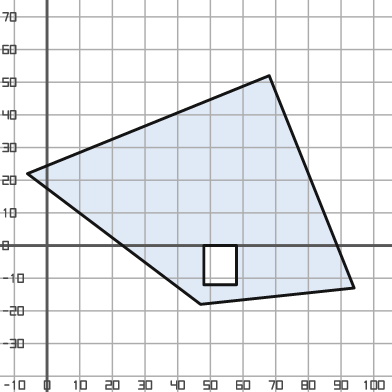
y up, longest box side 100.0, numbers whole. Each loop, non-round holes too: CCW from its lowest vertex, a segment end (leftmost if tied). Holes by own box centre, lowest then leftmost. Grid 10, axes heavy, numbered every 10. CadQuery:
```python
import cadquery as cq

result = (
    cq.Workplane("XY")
    .moveTo(47.0, -18.0)
    .lineTo(94.0, -13.0)
    .lineTo(68.0, 52.0)
    .lineTo(-6.0, 22.0)
    .close()
    .moveTo(48.0, -12.0)
    .lineTo(58.0, -12.0)
    .lineTo(58.0, 0.0)
    .lineTo(48.0, 0.0)
    .close()
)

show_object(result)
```